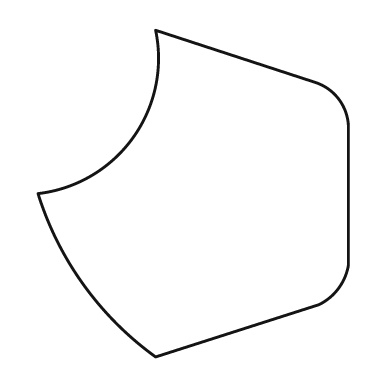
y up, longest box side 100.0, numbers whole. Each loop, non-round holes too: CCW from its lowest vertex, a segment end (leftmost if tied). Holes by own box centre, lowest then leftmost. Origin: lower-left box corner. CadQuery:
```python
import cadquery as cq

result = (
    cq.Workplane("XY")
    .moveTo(36.0, 0.0)
    .lineTo(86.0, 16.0)
    .threePointArc((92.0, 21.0), (95.0, 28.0))
    .lineTo(95.0, 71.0)
    .threePointArc((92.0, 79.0), (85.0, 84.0))
    .lineTo(36.0, 100.0)
    .threePointArc((29.0, 67.0), (0.0, 50.0))
    .threePointArc((14.0, 22.0), (36.0, 0.0))
    .close()
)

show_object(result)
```